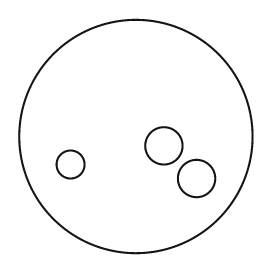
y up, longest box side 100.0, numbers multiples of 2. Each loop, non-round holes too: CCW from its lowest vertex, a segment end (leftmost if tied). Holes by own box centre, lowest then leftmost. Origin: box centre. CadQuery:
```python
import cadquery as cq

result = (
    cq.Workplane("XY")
    .moveTo(0.0, 0.0)
    .circle(50.0)
    .moveTo(26.0, -18.0)
    .circle(8.0)
    .moveTo(-28.0, -12.0)
    .circle(6.0)
    .moveTo(12.0, -4.0)
    .circle(8.0)
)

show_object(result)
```